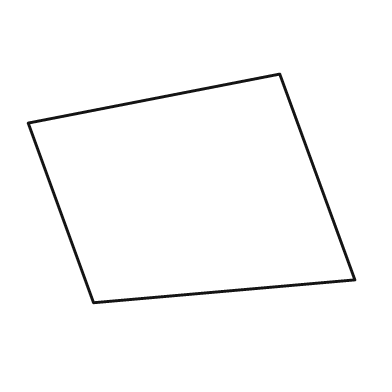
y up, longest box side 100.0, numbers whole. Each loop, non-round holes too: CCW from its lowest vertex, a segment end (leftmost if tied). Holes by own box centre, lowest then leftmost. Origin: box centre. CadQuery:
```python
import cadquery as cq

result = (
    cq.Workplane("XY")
    .moveTo(-30.0, -35.0)
    .lineTo(50.0, -28.0)
    .lineTo(27.0, 35.0)
    .lineTo(-50.0, 20.0)
    .close()
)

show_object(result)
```